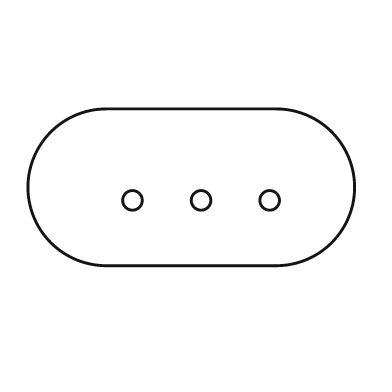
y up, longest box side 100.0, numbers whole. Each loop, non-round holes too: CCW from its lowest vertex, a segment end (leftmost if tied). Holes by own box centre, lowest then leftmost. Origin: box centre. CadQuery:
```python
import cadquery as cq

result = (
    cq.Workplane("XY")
    .moveTo(-26.0, -24.0)
    .lineTo(26.0, -24.0)
    .threePointArc((50.0, 0.0), (26.0, 24.0))
    .lineTo(-26.0, 24.0)
    .threePointArc((-50.0, 0.0), (-26.0, -24.0))
    .close()
    .moveTo(-18.0, -4.0)
    .circle(3.0)
    .moveTo(3.0, -4.0)
    .circle(3.0)
    .moveTo(24.0, -4.0)
    .circle(3.0)
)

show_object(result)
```